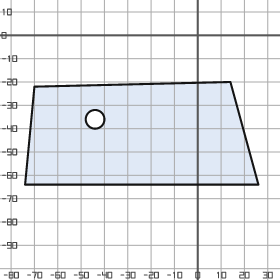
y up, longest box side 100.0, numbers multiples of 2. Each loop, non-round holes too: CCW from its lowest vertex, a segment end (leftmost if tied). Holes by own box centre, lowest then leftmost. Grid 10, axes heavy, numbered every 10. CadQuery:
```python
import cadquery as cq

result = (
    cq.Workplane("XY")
    .moveTo(-74.0, -64.0)
    .lineTo(26.0, -64.0)
    .lineTo(14.0, -20.0)
    .lineTo(-70.0, -22.0)
    .close()
    .moveTo(-44.0, -36.0)
    .circle(4.0)
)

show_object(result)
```